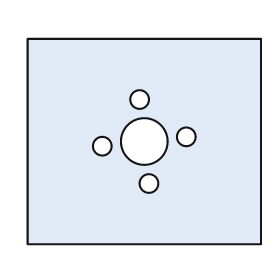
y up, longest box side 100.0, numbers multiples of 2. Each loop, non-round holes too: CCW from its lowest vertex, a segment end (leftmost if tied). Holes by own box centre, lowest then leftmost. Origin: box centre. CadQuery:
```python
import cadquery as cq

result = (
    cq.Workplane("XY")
    .moveTo(-50.0, -44.0)
    .lineTo(50.0, -44.0)
    .lineTo(50.0, 44.0)
    .lineTo(-50.0, 44.0)
    .close()
    .moveTo(2.0, -18.0)
    .circle(4.0)
    .moveTo(-18.0, -2.0)
    .circle(4.0)
    .moveTo(0.0, 0.0)
    .circle(10.0)
    .moveTo(18.0, 2.0)
    .circle(4.0)
    .moveTo(-2.0, 18.0)
    .circle(4.0)
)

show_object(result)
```